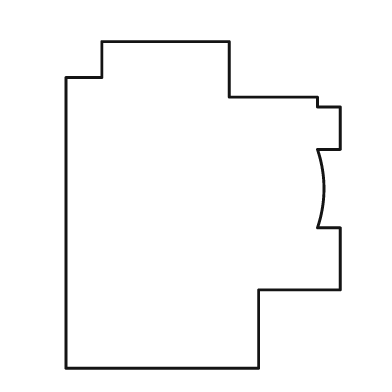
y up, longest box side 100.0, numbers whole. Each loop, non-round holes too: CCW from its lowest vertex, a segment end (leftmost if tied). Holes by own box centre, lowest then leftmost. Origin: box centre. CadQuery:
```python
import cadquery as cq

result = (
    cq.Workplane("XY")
    .moveTo(-42.0, -50.0)
    .lineTo(17.0, -50.0)
    .lineTo(17.0, -26.0)
    .lineTo(42.0, -26.0)
    .lineTo(42.0, -7.0)
    .lineTo(35.0, -7.0)
    .threePointArc((37.0, 5.0), (35.0, 17.0))
    .lineTo(42.0, 17.0)
    .lineTo(42.0, 30.0)
    .lineTo(35.0, 30.0)
    .lineTo(35.0, 33.0)
    .lineTo(8.0, 33.0)
    .lineTo(8.0, 50.0)
    .lineTo(-31.0, 50.0)
    .lineTo(-31.0, 39.0)
    .lineTo(-42.0, 39.0)
    .close()
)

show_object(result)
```